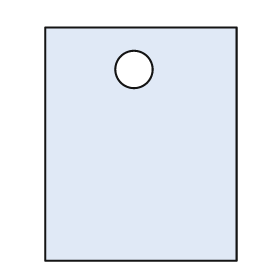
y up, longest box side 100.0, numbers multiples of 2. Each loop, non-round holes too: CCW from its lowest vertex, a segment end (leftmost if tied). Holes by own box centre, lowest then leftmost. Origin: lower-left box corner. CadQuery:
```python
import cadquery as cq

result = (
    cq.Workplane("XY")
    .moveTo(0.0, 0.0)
    .lineTo(82.0, 0.0)
    .lineTo(82.0, 100.0)
    .lineTo(0.0, 100.0)
    .close()
    .moveTo(38.0, 82.0)
    .circle(8.0)
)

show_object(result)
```